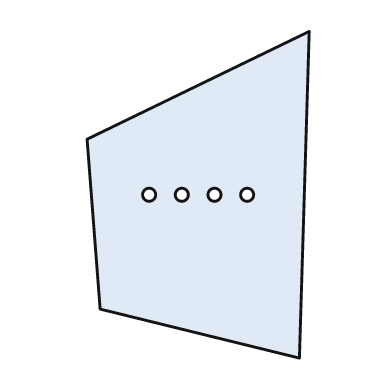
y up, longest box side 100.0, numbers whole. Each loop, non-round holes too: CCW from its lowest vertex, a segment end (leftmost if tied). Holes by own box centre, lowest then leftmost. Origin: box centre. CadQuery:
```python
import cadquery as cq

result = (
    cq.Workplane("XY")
    .moveTo(31.0, -50.0)
    .lineTo(34.0, 50.0)
    .lineTo(-34.0, 17.0)
    .lineTo(-30.0, -35.0)
    .close()
    .moveTo(-15.0, 0.0)
    .circle(2.0)
    .moveTo(-5.0, 0.0)
    .circle(2.0)
    .moveTo(5.0, 0.0)
    .circle(2.0)
    .moveTo(15.0, 0.0)
    .circle(2.0)
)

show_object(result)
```